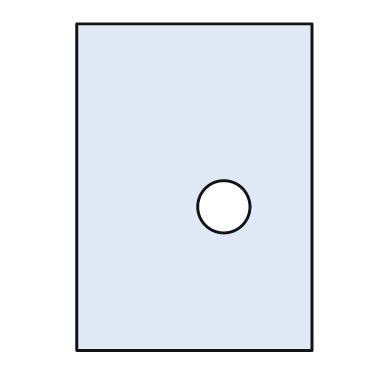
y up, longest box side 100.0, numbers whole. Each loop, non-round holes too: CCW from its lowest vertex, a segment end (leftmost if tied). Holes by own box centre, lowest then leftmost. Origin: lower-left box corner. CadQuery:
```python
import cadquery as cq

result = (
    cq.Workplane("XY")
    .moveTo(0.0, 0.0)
    .lineTo(72.0, 0.0)
    .lineTo(72.0, 100.0)
    .lineTo(0.0, 100.0)
    .close()
    .moveTo(45.0, 44.0)
    .circle(8.0)
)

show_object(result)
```